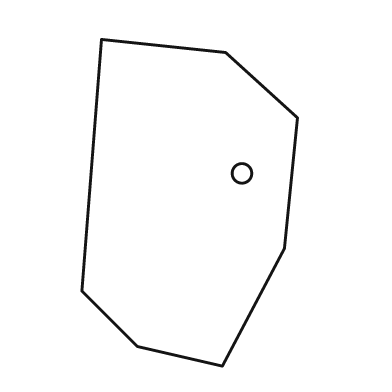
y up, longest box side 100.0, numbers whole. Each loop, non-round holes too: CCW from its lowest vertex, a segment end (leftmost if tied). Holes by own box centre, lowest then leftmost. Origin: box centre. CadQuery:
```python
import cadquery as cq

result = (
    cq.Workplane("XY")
    .moveTo(10.0, -50.0)
    .lineTo(29.0, -14.0)
    .lineTo(33.0, 26.0)
    .lineTo(11.0, 46.0)
    .lineTo(-27.0, 50.0)
    .lineTo(-33.0, -27.0)
    .lineTo(-16.0, -44.0)
    .close()
    .moveTo(16.0, 9.0)
    .circle(3.0)
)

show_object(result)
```